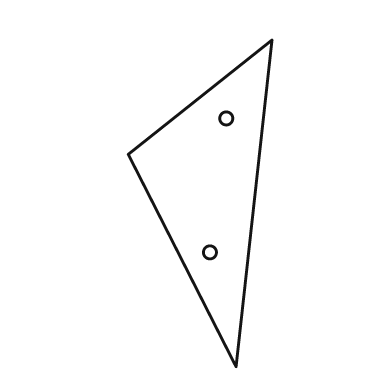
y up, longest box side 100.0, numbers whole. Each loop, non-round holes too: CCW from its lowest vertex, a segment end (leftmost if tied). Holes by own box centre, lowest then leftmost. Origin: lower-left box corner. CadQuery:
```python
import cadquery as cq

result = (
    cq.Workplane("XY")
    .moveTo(33.0, 0.0)
    .lineTo(44.0, 100.0)
    .lineTo(0.0, 65.0)
    .close()
    .moveTo(25.0, 35.0)
    .circle(2.0)
    .moveTo(30.0, 76.0)
    .circle(2.0)
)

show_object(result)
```